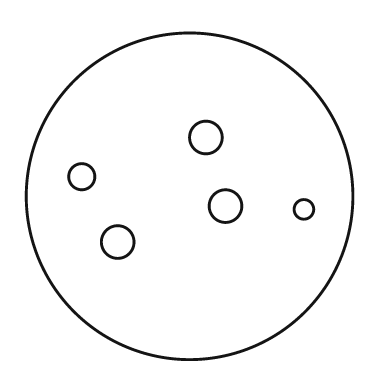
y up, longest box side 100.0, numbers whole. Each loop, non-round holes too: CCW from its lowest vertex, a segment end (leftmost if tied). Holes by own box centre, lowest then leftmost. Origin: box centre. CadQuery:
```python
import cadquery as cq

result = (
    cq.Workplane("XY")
    .moveTo(0.0, 0.0)
    .circle(50.0)
    .moveTo(-22.0, -14.0)
    .circle(5.0)
    .moveTo(35.0, -4.0)
    .circle(3.0)
    .moveTo(11.0, -3.0)
    .circle(5.0)
    .moveTo(-33.0, 6.0)
    .circle(4.0)
    .moveTo(5.0, 18.0)
    .circle(5.0)
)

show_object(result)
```